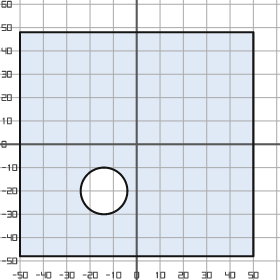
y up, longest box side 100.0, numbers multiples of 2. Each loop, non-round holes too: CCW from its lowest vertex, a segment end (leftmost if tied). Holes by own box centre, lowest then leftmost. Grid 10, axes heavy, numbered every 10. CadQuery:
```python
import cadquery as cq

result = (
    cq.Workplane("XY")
    .moveTo(-50.0, -48.0)
    .lineTo(50.0, -48.0)
    .lineTo(50.0, 48.0)
    .lineTo(-50.0, 48.0)
    .close()
    .moveTo(-14.0, -20.0)
    .circle(10.0)
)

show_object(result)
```